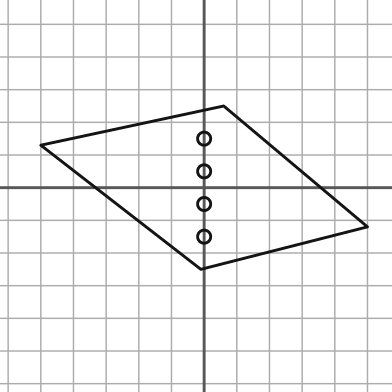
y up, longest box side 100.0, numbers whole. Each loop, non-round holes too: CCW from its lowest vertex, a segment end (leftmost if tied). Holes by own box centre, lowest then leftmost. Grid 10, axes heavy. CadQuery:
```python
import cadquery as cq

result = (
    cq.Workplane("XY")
    .moveTo(-1.0, -25.0)
    .lineTo(50.0, -12.0)
    .lineTo(6.0, 25.0)
    .lineTo(-50.0, 13.0)
    .close()
    .moveTo(0.0, -15.0)
    .circle(2.0)
    .moveTo(0.0, -5.0)
    .circle(2.0)
    .moveTo(0.0, 5.0)
    .circle(2.0)
    .moveTo(0.0, 15.0)
    .circle(2.0)
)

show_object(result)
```